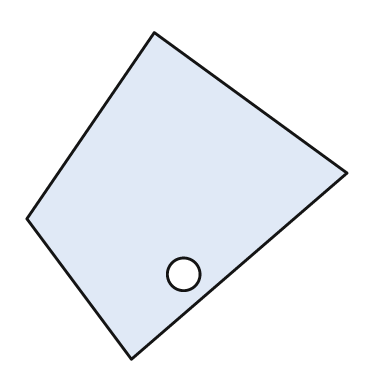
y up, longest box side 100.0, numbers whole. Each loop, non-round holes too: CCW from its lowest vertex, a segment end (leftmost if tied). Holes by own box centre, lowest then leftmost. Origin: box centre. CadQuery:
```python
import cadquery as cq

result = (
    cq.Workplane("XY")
    .moveTo(-17.0, -50.0)
    .lineTo(49.0, 7.0)
    .lineTo(-10.0, 50.0)
    .lineTo(-49.0, -7.0)
    .close()
    .moveTo(-1.0, -24.0)
    .circle(5.0)
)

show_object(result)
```